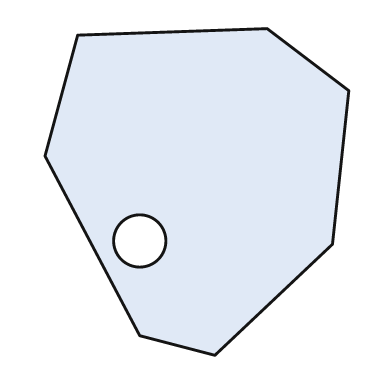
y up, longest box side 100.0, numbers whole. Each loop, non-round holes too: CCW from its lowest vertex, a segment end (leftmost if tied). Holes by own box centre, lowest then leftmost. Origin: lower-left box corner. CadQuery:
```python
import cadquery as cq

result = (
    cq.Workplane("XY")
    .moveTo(52.0, 0.0)
    .lineTo(88.0, 34.0)
    .lineTo(93.0, 81.0)
    .lineTo(68.0, 100.0)
    .lineTo(10.0, 98.0)
    .lineTo(0.0, 61.0)
    .lineTo(29.0, 6.0)
    .close()
    .moveTo(29.0, 35.0)
    .circle(8.0)
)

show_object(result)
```